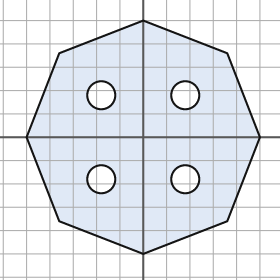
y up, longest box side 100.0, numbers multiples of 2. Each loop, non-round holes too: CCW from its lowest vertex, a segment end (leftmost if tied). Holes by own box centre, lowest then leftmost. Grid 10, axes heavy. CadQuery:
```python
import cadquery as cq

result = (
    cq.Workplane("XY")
    .moveTo(0.0, -50.0)
    .lineTo(36.0, -36.0)
    .lineTo(50.0, 0.0)
    .lineTo(36.0, 36.0)
    .lineTo(0.0, 50.0)
    .lineTo(-36.0, 36.0)
    .lineTo(-50.0, 0.0)
    .lineTo(-36.0, -36.0)
    .close()
    .moveTo(-18.0, -18.0)
    .circle(6.0)
    .moveTo(18.0, -18.0)
    .circle(6.0)
    .moveTo(-18.0, 18.0)
    .circle(6.0)
    .moveTo(18.0, 18.0)
    .circle(6.0)
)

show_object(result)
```